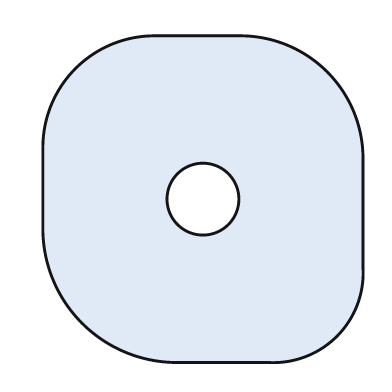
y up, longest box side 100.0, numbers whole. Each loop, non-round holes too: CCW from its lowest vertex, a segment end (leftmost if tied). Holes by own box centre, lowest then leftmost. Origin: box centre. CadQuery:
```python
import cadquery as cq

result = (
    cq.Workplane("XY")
    .moveTo(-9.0, -50.0)
    .lineTo(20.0, -50.0)
    .threePointArc((41.0, -42.0), (49.0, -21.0))
    .lineTo(49.0, 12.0)
    .threePointArc((38.0, 39.0), (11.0, 50.0))
    .lineTo(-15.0, 50.0)
    .threePointArc((-39.0, 40.0), (-49.0, 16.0))
    .lineTo(-49.0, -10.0)
    .threePointArc((-37.0, -38.0), (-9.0, -50.0))
    .close()
    .moveTo(0.0, 0.0)
    .circle(11.0)
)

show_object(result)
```